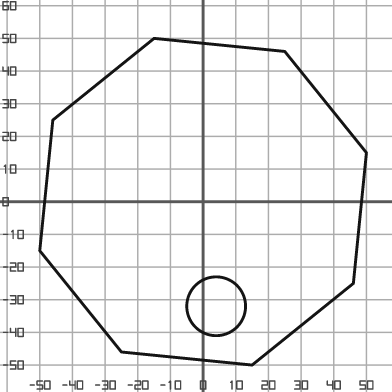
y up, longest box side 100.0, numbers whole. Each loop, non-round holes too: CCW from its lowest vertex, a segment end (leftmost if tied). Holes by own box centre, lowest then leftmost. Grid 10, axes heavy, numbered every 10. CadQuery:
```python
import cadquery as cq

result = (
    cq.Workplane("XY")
    .moveTo(15.0, -50.0)
    .lineTo(46.0, -25.0)
    .lineTo(50.0, 15.0)
    .lineTo(25.0, 46.0)
    .lineTo(-15.0, 50.0)
    .lineTo(-46.0, 25.0)
    .lineTo(-50.0, -15.0)
    .lineTo(-25.0, -46.0)
    .close()
    .moveTo(4.0, -32.0)
    .circle(9.0)
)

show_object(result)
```